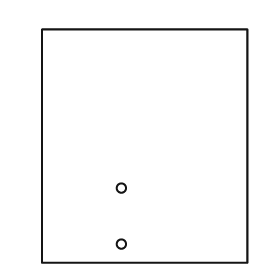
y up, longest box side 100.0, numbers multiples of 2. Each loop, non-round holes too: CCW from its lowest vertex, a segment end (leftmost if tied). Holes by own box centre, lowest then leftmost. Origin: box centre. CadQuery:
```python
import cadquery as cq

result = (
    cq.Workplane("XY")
    .moveTo(-44.0, -50.0)
    .lineTo(44.0, -50.0)
    .lineTo(44.0, 50.0)
    .lineTo(-44.0, 50.0)
    .close()
    .moveTo(-10.0, -42.0)
    .circle(2.0)
    .moveTo(-10.0, -18.0)
    .circle(2.0)
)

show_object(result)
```